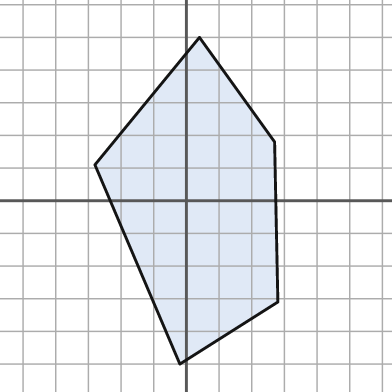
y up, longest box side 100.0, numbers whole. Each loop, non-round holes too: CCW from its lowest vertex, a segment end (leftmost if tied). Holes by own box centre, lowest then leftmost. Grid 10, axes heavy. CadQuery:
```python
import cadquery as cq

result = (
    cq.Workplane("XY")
    .moveTo(-2.0, -50.0)
    .lineTo(28.0, -31.0)
    .lineTo(27.0, 18.0)
    .lineTo(4.0, 50.0)
    .lineTo(-28.0, 11.0)
    .close()
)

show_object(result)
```